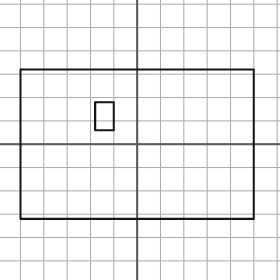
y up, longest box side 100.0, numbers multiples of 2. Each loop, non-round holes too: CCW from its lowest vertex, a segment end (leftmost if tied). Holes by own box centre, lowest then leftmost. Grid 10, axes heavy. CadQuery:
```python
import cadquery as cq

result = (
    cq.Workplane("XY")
    .moveTo(-50.0, -32.0)
    .lineTo(50.0, -32.0)
    .lineTo(50.0, 32.0)
    .lineTo(-50.0, 32.0)
    .close()
    .moveTo(-18.0, 6.0)
    .lineTo(-10.0, 6.0)
    .lineTo(-10.0, 18.0)
    .lineTo(-18.0, 18.0)
    .close()
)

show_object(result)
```